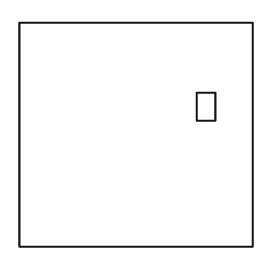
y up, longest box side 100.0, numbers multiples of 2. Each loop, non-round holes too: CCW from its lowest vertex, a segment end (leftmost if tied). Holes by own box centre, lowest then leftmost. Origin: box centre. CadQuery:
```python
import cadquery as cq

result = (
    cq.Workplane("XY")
    .moveTo(-50.0, -48.0)
    .lineTo(50.0, -48.0)
    .lineTo(50.0, 48.0)
    .lineTo(-50.0, 48.0)
    .close()
    .moveTo(26.0, 6.0)
    .lineTo(34.0, 6.0)
    .lineTo(34.0, 18.0)
    .lineTo(26.0, 18.0)
    .close()
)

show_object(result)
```